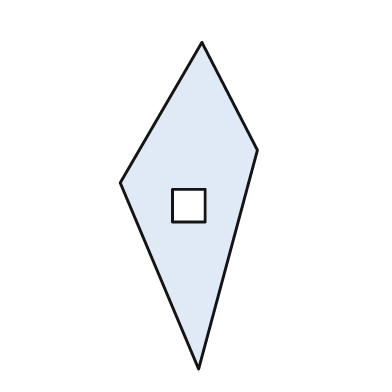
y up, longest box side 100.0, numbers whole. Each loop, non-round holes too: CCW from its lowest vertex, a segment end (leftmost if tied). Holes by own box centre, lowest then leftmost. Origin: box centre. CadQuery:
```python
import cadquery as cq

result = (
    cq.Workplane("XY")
    .moveTo(3.0, -50.0)
    .lineTo(21.0, 17.0)
    .lineTo(4.0, 50.0)
    .lineTo(-21.0, 7.0)
    .close()
    .moveTo(-5.0, -5.0)
    .lineTo(5.0, -5.0)
    .lineTo(5.0, 5.0)
    .lineTo(-5.0, 5.0)
    .close()
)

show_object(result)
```